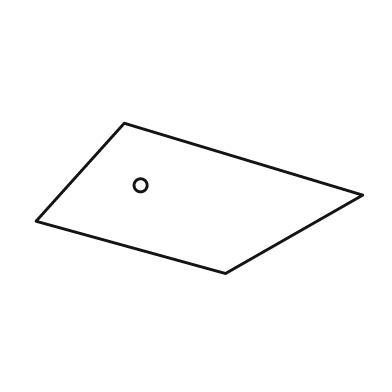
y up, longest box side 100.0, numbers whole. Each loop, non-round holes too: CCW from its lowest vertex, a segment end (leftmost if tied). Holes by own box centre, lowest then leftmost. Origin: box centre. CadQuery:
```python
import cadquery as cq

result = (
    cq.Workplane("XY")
    .moveTo(8.0, -23.0)
    .lineTo(50.0, 1.0)
    .lineTo(-23.0, 23.0)
    .lineTo(-50.0, -7.0)
    .close()
    .moveTo(-18.0, 4.0)
    .circle(2.0)
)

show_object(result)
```